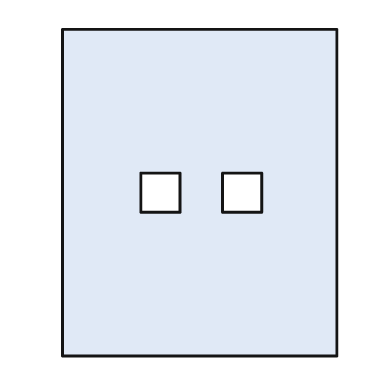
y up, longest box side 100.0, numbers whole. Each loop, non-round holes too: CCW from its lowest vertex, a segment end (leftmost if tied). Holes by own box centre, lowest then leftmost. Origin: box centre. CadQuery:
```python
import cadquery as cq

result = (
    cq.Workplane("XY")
    .moveTo(-42.0, -50.0)
    .lineTo(42.0, -50.0)
    .lineTo(42.0, 50.0)
    .lineTo(-42.0, 50.0)
    .close()
    .moveTo(-18.0, -6.0)
    .lineTo(-6.0, -6.0)
    .lineTo(-6.0, 6.0)
    .lineTo(-18.0, 6.0)
    .close()
    .moveTo(7.0, -6.0)
    .lineTo(19.0, -6.0)
    .lineTo(19.0, 6.0)
    .lineTo(7.0, 6.0)
    .close()
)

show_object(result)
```